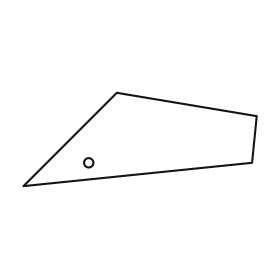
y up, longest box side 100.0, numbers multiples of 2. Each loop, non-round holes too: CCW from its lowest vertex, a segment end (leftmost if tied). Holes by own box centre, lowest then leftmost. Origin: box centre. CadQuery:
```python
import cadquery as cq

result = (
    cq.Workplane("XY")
    .moveTo(-50.0, -20.0)
    .lineTo(48.0, -10.0)
    .lineTo(50.0, 10.0)
    .lineTo(-10.0, 20.0)
    .close()
    .moveTo(-22.0, -10.0)
    .circle(2.0)
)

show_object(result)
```